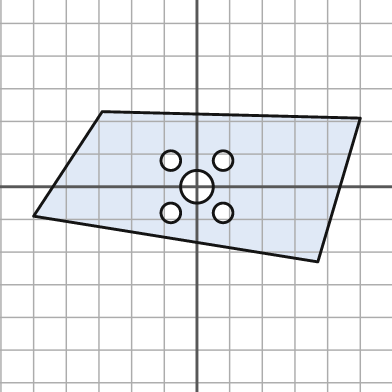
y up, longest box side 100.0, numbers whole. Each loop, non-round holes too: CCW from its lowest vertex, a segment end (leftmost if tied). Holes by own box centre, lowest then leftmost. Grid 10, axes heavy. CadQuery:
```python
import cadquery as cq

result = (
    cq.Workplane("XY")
    .moveTo(37.0, -23.0)
    .lineTo(50.0, 21.0)
    .lineTo(-29.0, 23.0)
    .lineTo(-50.0, -9.0)
    .close()
    .moveTo(-8.0, -8.0)
    .circle(3.0)
    .moveTo(8.0, -8.0)
    .circle(3.0)
    .moveTo(0.0, 0.0)
    .circle(5.0)
    .moveTo(-8.0, 8.0)
    .circle(3.0)
    .moveTo(8.0, 8.0)
    .circle(3.0)
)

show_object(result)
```